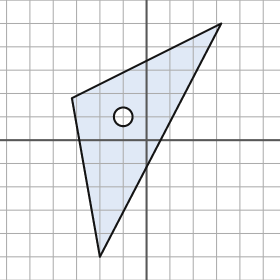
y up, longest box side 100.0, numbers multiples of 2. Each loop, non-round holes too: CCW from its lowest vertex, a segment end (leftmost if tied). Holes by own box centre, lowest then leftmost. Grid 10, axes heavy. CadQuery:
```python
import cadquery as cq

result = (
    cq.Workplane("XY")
    .moveTo(-20.0, -50.0)
    .lineTo(32.0, 50.0)
    .lineTo(-32.0, 18.0)
    .close()
    .moveTo(-10.0, 10.0)
    .circle(4.0)
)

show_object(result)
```